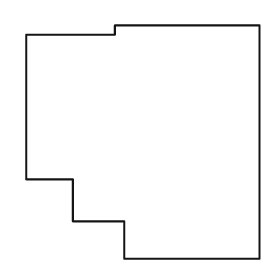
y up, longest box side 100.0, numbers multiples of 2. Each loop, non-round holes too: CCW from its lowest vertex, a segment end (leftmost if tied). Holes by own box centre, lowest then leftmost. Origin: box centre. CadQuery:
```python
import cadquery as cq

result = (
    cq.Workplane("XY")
    .moveTo(-8.0, -50.0)
    .lineTo(50.0, -50.0)
    .lineTo(50.0, 50.0)
    .lineTo(-12.0, 50.0)
    .lineTo(-12.0, 46.0)
    .lineTo(-50.0, 46.0)
    .lineTo(-50.0, -16.0)
    .lineTo(-30.0, -16.0)
    .lineTo(-30.0, -34.0)
    .lineTo(-8.0, -34.0)
    .close()
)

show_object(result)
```